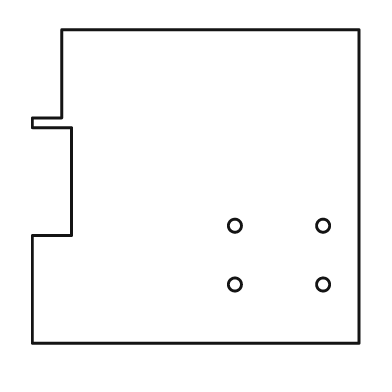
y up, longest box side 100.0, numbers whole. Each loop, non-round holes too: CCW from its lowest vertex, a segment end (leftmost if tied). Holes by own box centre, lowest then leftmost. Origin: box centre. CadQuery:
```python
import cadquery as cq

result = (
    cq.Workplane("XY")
    .moveTo(-50.0, -48.0)
    .lineTo(50.0, -48.0)
    .lineTo(50.0, 48.0)
    .lineTo(-41.0, 48.0)
    .lineTo(-41.0, 21.0)
    .lineTo(-50.0, 21.0)
    .lineTo(-50.0, 18.0)
    .lineTo(-38.0, 18.0)
    .lineTo(-38.0, -15.0)
    .lineTo(-50.0, -15.0)
    .close()
    .moveTo(12.0, -30.0)
    .circle(2.0)
    .moveTo(39.0, -30.0)
    .circle(2.0)
    .moveTo(12.0, -12.0)
    .circle(2.0)
    .moveTo(39.0, -12.0)
    .circle(2.0)
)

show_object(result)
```